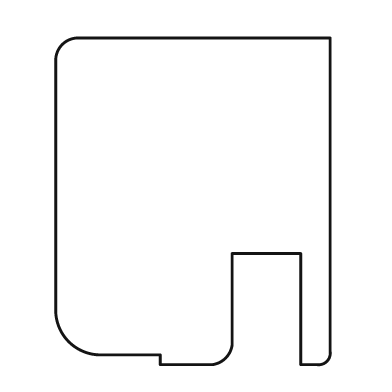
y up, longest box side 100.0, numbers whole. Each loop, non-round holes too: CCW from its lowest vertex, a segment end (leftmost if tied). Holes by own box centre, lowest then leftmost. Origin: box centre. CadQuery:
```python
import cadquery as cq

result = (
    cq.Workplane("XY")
    .moveTo(-10.0, -50.0)
    .lineTo(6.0, -50.0)
    .threePointArc((10.0, -48.0), (12.0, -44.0))
    .lineTo(12.0, -16.0)
    .lineTo(33.0, -16.0)
    .lineTo(33.0, -50.0)
    .lineTo(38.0, -50.0)
    .threePointArc((41.0, -49.0), (42.0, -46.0))
    .lineTo(42.0, 50.0)
    .lineTo(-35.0, 50.0)
    .threePointArc((-40.0, 48.0), (-42.0, 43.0))
    .lineTo(-42.0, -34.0)
    .threePointArc((-38.0, -43.0), (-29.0, -47.0))
    .lineTo(-10.0, -47.0)
    .close()
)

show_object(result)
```